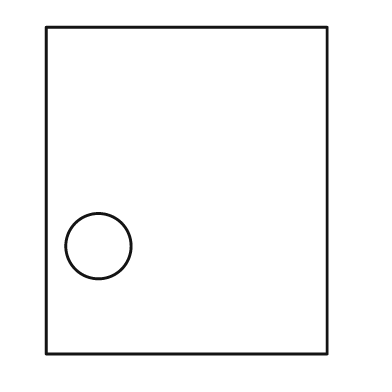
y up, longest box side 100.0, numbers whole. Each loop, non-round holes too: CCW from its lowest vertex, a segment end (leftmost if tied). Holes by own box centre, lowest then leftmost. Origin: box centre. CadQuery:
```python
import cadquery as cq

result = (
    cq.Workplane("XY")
    .moveTo(-43.0, -50.0)
    .lineTo(43.0, -50.0)
    .lineTo(43.0, 50.0)
    .lineTo(-43.0, 50.0)
    .close()
    .moveTo(-27.0, -17.0)
    .circle(10.0)
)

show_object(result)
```